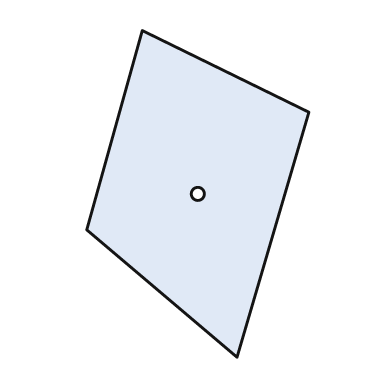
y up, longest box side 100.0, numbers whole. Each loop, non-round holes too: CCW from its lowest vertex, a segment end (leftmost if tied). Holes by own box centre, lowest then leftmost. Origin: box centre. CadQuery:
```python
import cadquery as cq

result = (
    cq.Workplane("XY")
    .moveTo(12.0, -50.0)
    .lineTo(34.0, 25.0)
    .lineTo(-17.0, 50.0)
    .lineTo(-34.0, -11.0)
    .close()
    .moveTo(0.0, 0.0)
    .circle(2.0)
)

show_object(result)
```